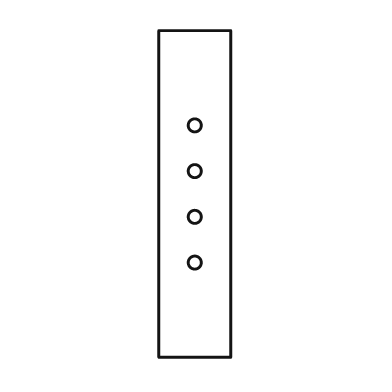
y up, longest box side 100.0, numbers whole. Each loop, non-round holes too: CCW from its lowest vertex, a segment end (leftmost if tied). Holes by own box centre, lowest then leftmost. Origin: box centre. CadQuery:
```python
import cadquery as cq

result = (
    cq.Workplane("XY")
    .moveTo(-11.0, -50.0)
    .lineTo(11.0, -50.0)
    .lineTo(11.0, 50.0)
    .lineTo(-11.0, 50.0)
    .close()
    .moveTo(0.0, -21.0)
    .circle(2.0)
    .moveTo(0.0, -7.0)
    .circle(2.0)
    .moveTo(0.0, 7.0)
    .circle(2.0)
    .moveTo(0.0, 21.0)
    .circle(2.0)
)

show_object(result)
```